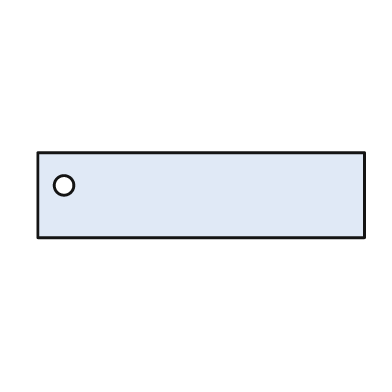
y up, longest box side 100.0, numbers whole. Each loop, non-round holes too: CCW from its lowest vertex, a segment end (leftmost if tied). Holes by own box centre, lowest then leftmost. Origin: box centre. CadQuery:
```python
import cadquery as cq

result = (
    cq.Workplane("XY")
    .moveTo(-50.0, -13.0)
    .lineTo(50.0, -13.0)
    .lineTo(50.0, 13.0)
    .lineTo(-50.0, 13.0)
    .close()
    .moveTo(-42.0, 3.0)
    .circle(3.0)
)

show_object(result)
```